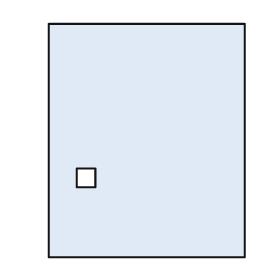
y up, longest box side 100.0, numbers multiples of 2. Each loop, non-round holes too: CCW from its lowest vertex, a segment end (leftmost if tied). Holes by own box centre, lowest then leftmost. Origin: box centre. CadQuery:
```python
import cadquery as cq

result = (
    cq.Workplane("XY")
    .moveTo(-42.0, -50.0)
    .lineTo(42.0, -50.0)
    .lineTo(42.0, 50.0)
    .lineTo(-42.0, 50.0)
    .close()
    .moveTo(-30.0, -20.0)
    .lineTo(-22.0, -20.0)
    .lineTo(-22.0, -12.0)
    .lineTo(-30.0, -12.0)
    .close()
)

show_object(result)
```